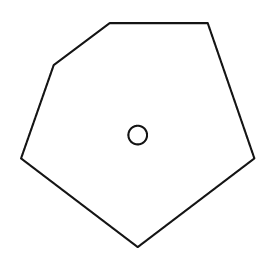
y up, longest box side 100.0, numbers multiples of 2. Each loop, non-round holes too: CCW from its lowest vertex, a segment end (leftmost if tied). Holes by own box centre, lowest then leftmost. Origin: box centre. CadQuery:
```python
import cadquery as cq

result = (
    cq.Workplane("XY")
    .moveTo(0.0, -48.0)
    .lineTo(50.0, -10.0)
    .lineTo(30.0, 48.0)
    .lineTo(-12.0, 48.0)
    .lineTo(-36.0, 30.0)
    .lineTo(-50.0, -10.0)
    .close()
    .moveTo(0.0, 0.0)
    .circle(4.0)
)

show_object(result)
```